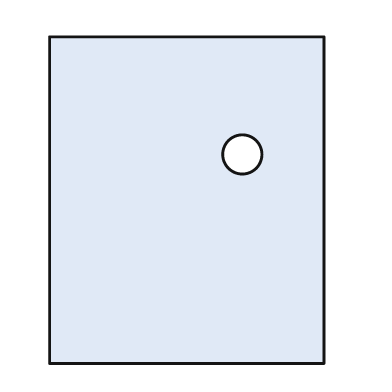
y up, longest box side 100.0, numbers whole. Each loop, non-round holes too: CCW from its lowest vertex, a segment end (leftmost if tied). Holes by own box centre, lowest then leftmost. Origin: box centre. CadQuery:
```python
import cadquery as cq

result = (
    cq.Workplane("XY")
    .moveTo(-42.0, -50.0)
    .lineTo(42.0, -50.0)
    .lineTo(42.0, 50.0)
    .lineTo(-42.0, 50.0)
    .close()
    .moveTo(17.0, 14.0)
    .circle(6.0)
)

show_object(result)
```